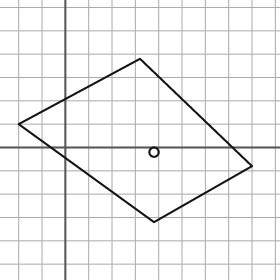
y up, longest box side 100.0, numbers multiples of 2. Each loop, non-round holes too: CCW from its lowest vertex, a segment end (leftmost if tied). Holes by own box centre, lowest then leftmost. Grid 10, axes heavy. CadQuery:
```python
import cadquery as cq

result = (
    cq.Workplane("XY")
    .moveTo(38.0, -32.0)
    .lineTo(80.0, -8.0)
    .lineTo(32.0, 38.0)
    .lineTo(-20.0, 10.0)
    .close()
    .moveTo(38.0, -2.0)
    .circle(2.0)
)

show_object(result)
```